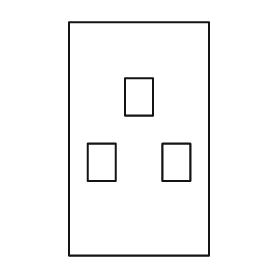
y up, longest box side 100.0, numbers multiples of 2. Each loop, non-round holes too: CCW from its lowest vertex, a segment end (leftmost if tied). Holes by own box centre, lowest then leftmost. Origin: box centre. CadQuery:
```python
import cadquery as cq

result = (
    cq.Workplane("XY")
    .moveTo(-30.0, -50.0)
    .lineTo(30.0, -50.0)
    .lineTo(30.0, 50.0)
    .lineTo(-30.0, 50.0)
    .close()
    .moveTo(-22.0, -18.0)
    .lineTo(-10.0, -18.0)
    .lineTo(-10.0, -2.0)
    .lineTo(-22.0, -2.0)
    .close()
    .moveTo(10.0, -18.0)
    .lineTo(22.0, -18.0)
    .lineTo(22.0, -2.0)
    .lineTo(10.0, -2.0)
    .close()
    .moveTo(-6.0, 10.0)
    .lineTo(6.0, 10.0)
    .lineTo(6.0, 26.0)
    .lineTo(-6.0, 26.0)
    .close()
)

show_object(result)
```